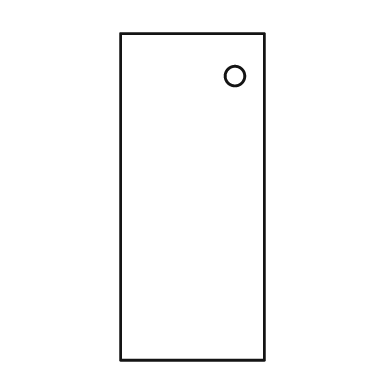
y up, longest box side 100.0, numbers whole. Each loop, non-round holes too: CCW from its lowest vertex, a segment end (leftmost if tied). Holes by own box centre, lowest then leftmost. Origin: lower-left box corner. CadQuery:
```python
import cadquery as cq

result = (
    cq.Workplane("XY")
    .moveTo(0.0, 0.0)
    .lineTo(44.0, 0.0)
    .lineTo(44.0, 100.0)
    .lineTo(0.0, 100.0)
    .close()
    .moveTo(35.0, 87.0)
    .circle(3.0)
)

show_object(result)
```